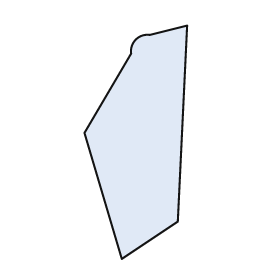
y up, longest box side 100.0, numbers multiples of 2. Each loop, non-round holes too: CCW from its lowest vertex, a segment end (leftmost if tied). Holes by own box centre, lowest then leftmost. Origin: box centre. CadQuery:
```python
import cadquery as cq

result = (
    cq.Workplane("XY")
    .moveTo(-6.0, -50.0)
    .lineTo(18.0, -34.0)
    .lineTo(22.0, 50.0)
    .lineTo(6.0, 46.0)
    .threePointArc((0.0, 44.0), (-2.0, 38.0))
    .lineTo(-22.0, 4.0)
    .close()
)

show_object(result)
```